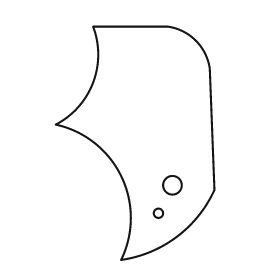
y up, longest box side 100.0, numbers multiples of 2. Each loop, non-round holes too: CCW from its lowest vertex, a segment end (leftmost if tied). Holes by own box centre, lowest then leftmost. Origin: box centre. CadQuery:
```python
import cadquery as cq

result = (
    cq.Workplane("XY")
    .moveTo(-6.0, -50.0)
    .threePointArc((18.0, -40.0), (34.0, -20.0))
    .lineTo(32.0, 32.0)
    .threePointArc((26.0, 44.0), (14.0, 50.0))
    .lineTo(-18.0, 50.0)
    .threePointArc((-18.0, 26.0), (-34.0, 8.0))
    .threePointArc((-6.0, -14.0), (-6.0, -50.0))
    .close()
    .moveTo(10.0, -30.0)
    .circle(2.0)
    .moveTo(16.0, -18.0)
    .circle(4.0)
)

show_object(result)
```